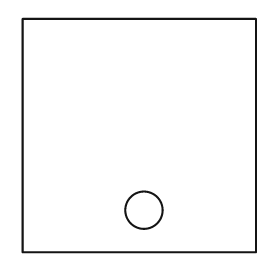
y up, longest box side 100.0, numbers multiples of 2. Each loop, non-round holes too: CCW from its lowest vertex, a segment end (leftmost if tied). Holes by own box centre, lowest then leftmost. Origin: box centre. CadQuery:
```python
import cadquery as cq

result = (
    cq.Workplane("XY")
    .moveTo(-50.0, -50.0)
    .lineTo(50.0, -50.0)
    .lineTo(50.0, 50.0)
    .lineTo(-50.0, 50.0)
    .close()
    .moveTo(2.0, -32.0)
    .circle(8.0)
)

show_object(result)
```